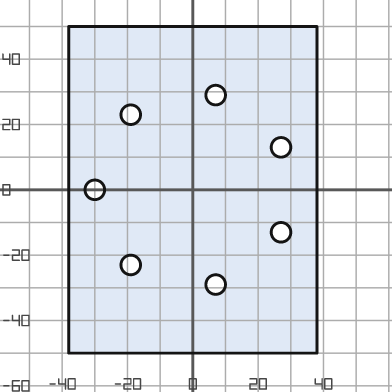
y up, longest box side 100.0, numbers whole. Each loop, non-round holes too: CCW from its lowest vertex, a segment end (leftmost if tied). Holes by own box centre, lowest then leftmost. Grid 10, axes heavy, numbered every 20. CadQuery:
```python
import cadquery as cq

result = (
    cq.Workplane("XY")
    .moveTo(-38.0, -50.0)
    .lineTo(38.0, -50.0)
    .lineTo(38.0, 50.0)
    .lineTo(-38.0, 50.0)
    .close()
    .moveTo(7.0, -29.0)
    .circle(3.0)
    .moveTo(-19.0, -23.0)
    .circle(3.0)
    .moveTo(27.0, -13.0)
    .circle(3.0)
    .moveTo(-30.0, 0.0)
    .circle(3.0)
    .moveTo(27.0, 13.0)
    .circle(3.0)
    .moveTo(-19.0, 23.0)
    .circle(3.0)
    .moveTo(7.0, 29.0)
    .circle(3.0)
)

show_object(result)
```